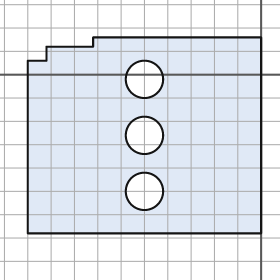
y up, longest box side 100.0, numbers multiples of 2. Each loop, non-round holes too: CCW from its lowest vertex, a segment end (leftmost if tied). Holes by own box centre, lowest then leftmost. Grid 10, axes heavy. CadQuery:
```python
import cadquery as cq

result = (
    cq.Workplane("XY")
    .moveTo(-100.0, -68.0)
    .lineTo(0.0, -68.0)
    .lineTo(0.0, 16.0)
    .lineTo(-72.0, 16.0)
    .lineTo(-72.0, 12.0)
    .lineTo(-92.0, 12.0)
    .lineTo(-92.0, 6.0)
    .lineTo(-100.0, 6.0)
    .close()
    .moveTo(-50.0, -50.0)
    .circle(8.0)
    .moveTo(-50.0, -26.0)
    .circle(8.0)
    .moveTo(-50.0, -2.0)
    .circle(8.0)
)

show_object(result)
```